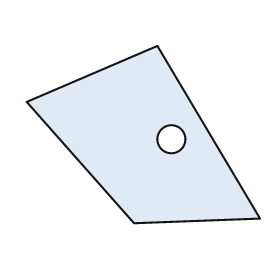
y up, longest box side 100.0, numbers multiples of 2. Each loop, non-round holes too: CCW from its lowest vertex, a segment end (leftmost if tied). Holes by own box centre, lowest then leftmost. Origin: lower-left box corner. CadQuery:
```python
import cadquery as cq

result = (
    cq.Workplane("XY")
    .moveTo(46.0, 0.0)
    .lineTo(100.0, 2.0)
    .lineTo(56.0, 76.0)
    .lineTo(0.0, 52.0)
    .close()
    .moveTo(62.0, 36.0)
    .circle(6.0)
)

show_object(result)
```